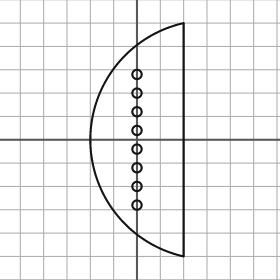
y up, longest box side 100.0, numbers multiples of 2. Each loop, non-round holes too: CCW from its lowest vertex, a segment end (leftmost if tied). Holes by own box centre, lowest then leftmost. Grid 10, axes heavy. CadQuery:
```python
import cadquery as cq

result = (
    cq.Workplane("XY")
    .moveTo(20.0, -50.0)
    .lineTo(20.0, 50.0)
    .threePointArc((-20.0, 0.0), (20.0, -50.0))
    .close()
    .moveTo(0.0, -28.0)
    .circle(2.0)
    .moveTo(0.0, -20.0)
    .circle(2.0)
    .moveTo(0.0, -12.0)
    .circle(2.0)
    .moveTo(0.0, -4.0)
    .circle(2.0)
    .moveTo(0.0, 4.0)
    .circle(2.0)
    .moveTo(0.0, 12.0)
    .circle(2.0)
    .moveTo(0.0, 20.0)
    .circle(2.0)
    .moveTo(0.0, 28.0)
    .circle(2.0)
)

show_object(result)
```